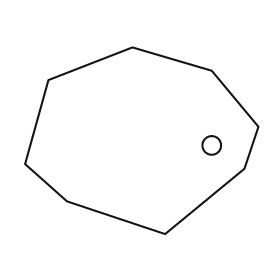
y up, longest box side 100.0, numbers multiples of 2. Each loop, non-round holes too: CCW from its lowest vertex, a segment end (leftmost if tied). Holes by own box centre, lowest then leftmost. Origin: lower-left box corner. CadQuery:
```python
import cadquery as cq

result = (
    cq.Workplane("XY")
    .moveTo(60.0, 0.0)
    .lineTo(94.0, 28.0)
    .lineTo(100.0, 46.0)
    .lineTo(80.0, 70.0)
    .lineTo(46.0, 80.0)
    .lineTo(10.0, 66.0)
    .lineTo(0.0, 30.0)
    .lineTo(18.0, 14.0)
    .close()
    .moveTo(80.0, 38.0)
    .circle(4.0)
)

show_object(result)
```